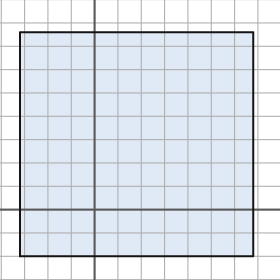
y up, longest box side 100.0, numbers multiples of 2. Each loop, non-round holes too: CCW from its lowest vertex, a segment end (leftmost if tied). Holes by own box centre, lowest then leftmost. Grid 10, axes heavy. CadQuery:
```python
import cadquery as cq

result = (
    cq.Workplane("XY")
    .moveTo(-32.0, -20.0)
    .lineTo(68.0, -20.0)
    .lineTo(68.0, 76.0)
    .lineTo(-32.0, 76.0)
    .close()
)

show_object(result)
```